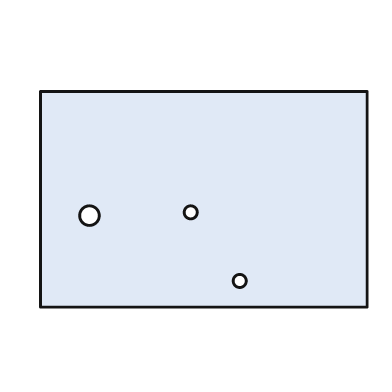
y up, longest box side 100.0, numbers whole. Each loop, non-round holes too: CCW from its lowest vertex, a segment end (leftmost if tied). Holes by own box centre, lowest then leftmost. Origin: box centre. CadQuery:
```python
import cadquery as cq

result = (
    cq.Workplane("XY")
    .moveTo(-50.0, -33.0)
    .lineTo(50.0, -33.0)
    .lineTo(50.0, 33.0)
    .lineTo(-50.0, 33.0)
    .close()
    .moveTo(11.0, -25.0)
    .circle(2.0)
    .moveTo(-35.0, -5.0)
    .circle(3.0)
    .moveTo(-4.0, -4.0)
    .circle(2.0)
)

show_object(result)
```